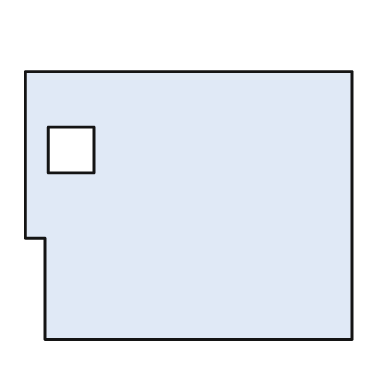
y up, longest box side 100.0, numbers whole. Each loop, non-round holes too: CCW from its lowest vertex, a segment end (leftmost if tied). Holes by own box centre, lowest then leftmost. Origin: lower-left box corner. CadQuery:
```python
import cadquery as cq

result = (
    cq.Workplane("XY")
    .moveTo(6.0, 0.0)
    .lineTo(100.0, 0.0)
    .lineTo(100.0, 82.0)
    .lineTo(0.0, 82.0)
    .lineTo(0.0, 31.0)
    .lineTo(6.0, 31.0)
    .close()
    .moveTo(7.0, 51.0)
    .lineTo(21.0, 51.0)
    .lineTo(21.0, 65.0)
    .lineTo(7.0, 65.0)
    .close()
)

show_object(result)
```